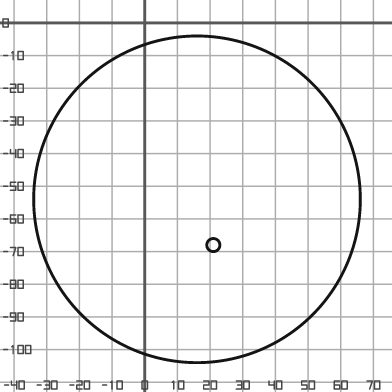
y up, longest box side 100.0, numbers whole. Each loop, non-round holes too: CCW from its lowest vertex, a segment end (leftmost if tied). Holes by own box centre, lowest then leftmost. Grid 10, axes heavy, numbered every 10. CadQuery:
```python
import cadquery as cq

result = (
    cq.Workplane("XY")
    .moveTo(16.0, -54.0)
    .circle(50.0)
    .moveTo(21.0, -68.0)
    .circle(2.0)
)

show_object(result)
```